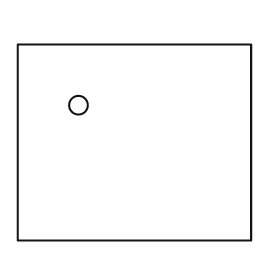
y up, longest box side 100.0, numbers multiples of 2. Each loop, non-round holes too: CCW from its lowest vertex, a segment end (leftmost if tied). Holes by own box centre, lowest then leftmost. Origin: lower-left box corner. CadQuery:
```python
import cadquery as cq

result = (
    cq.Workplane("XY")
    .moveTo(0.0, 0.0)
    .lineTo(100.0, 0.0)
    .lineTo(100.0, 84.0)
    .lineTo(0.0, 84.0)
    .close()
    .moveTo(26.0, 58.0)
    .circle(4.0)
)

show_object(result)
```